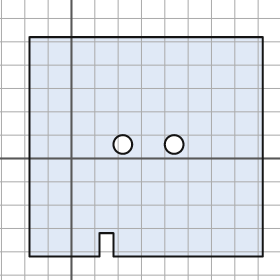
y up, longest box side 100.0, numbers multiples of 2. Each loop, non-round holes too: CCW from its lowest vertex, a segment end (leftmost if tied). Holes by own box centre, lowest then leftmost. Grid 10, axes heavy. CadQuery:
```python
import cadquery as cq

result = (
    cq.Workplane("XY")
    .moveTo(-18.0, -42.0)
    .lineTo(12.0, -42.0)
    .lineTo(12.0, -32.0)
    .lineTo(18.0, -32.0)
    .lineTo(18.0, -42.0)
    .lineTo(82.0, -42.0)
    .lineTo(82.0, 52.0)
    .lineTo(-18.0, 52.0)
    .close()
    .moveTo(22.0, 6.0)
    .circle(4.0)
    .moveTo(44.0, 6.0)
    .circle(4.0)
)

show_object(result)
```